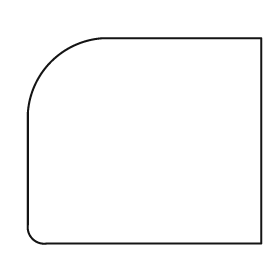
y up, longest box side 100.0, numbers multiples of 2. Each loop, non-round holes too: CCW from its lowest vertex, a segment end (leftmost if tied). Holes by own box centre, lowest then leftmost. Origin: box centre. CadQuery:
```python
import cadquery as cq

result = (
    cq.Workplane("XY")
    .moveTo(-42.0, -44.0)
    .lineTo(50.0, -44.0)
    .lineTo(50.0, 44.0)
    .lineTo(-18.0, 44.0)
    .threePointArc((-40.0, 34.0), (-50.0, 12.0))
    .lineTo(-50.0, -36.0)
    .threePointArc((-48.0, -42.0), (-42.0, -44.0))
    .close()
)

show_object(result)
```